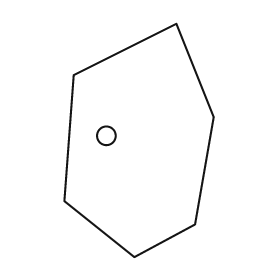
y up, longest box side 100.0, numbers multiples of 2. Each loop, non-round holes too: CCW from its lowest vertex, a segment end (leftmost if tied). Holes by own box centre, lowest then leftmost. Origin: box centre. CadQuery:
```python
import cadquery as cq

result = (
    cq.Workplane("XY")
    .moveTo(-2.0, -50.0)
    .lineTo(24.0, -36.0)
    .lineTo(32.0, 10.0)
    .lineTo(16.0, 50.0)
    .lineTo(-28.0, 28.0)
    .lineTo(-32.0, -26.0)
    .close()
    .moveTo(-14.0, 2.0)
    .circle(4.0)
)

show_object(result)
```